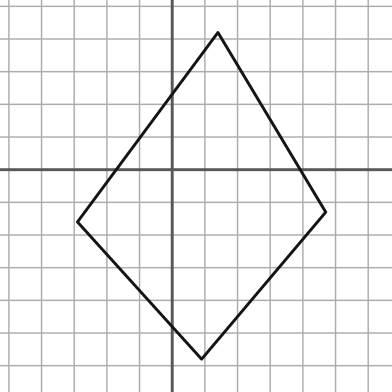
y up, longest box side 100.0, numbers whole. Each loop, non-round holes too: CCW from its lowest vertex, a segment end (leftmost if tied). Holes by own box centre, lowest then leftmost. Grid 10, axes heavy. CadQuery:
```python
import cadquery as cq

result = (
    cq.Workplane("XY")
    .moveTo(9.0, -58.0)
    .lineTo(47.0, -13.0)
    .lineTo(14.0, 42.0)
    .lineTo(-29.0, -16.0)
    .close()
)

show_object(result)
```